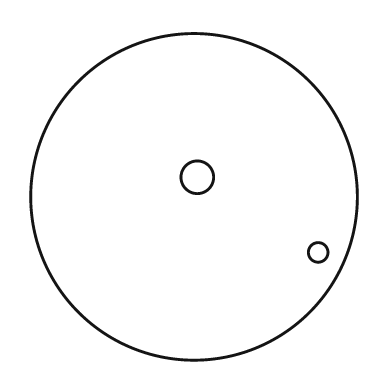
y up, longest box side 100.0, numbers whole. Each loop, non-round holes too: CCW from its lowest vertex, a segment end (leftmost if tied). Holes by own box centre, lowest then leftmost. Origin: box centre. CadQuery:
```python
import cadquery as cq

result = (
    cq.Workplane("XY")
    .moveTo(0.0, 0.0)
    .circle(50.0)
    .moveTo(38.0, -17.0)
    .circle(3.0)
    .moveTo(1.0, 6.0)
    .circle(5.0)
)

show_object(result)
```